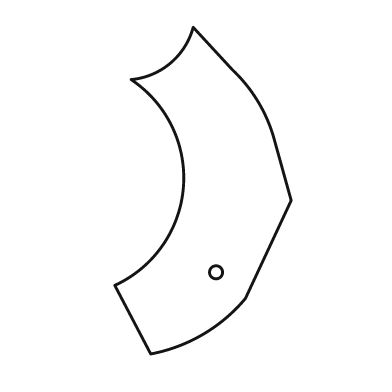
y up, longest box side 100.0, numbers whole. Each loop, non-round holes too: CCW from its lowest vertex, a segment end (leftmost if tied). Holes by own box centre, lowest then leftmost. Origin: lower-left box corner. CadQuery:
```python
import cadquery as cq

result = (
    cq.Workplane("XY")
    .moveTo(11.0, 0.0)
    .threePointArc((27.0, 6.0), (40.0, 17.0))
    .lineTo(54.0, 47.0)
    .lineTo(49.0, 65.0)
    .threePointArc((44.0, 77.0), (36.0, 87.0))
    .lineTo(24.0, 100.0)
    .threePointArc((17.0, 89.0), (5.0, 84.0))
    .threePointArc((21.0, 51.0), (0.0, 21.0))
    .close()
    .moveTo(31.0, 25.0)
    .circle(2.0)
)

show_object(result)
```